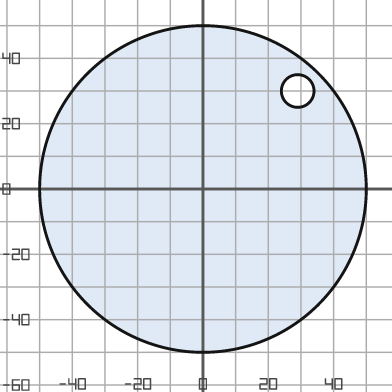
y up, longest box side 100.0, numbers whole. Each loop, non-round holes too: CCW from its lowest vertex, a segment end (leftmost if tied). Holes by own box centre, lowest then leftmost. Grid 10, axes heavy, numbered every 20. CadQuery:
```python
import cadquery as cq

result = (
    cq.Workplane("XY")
    .moveTo(0.0, 0.0)
    .circle(50.0)
    .moveTo(29.0, 30.0)
    .circle(5.0)
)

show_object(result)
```